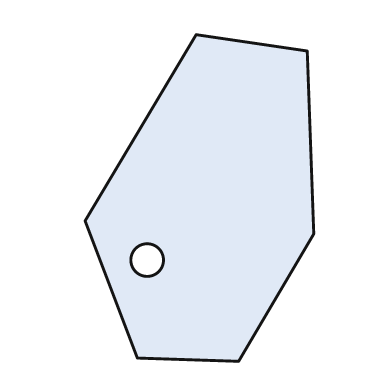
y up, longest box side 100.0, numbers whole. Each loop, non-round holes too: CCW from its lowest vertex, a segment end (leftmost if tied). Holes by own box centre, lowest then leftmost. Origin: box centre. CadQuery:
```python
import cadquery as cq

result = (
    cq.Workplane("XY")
    .moveTo(12.0, -50.0)
    .lineTo(35.0, -11.0)
    .lineTo(33.0, 45.0)
    .lineTo(-1.0, 50.0)
    .lineTo(-35.0, -7.0)
    .lineTo(-19.0, -49.0)
    .close()
    .moveTo(-16.0, -19.0)
    .circle(5.0)
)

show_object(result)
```